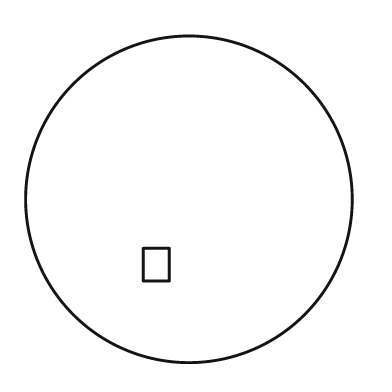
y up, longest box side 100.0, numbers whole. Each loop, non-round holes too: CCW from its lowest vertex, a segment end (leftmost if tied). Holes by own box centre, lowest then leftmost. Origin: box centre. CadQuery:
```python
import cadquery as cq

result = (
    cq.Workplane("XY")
    .moveTo(0.0, 0.0)
    .circle(50.0)
    .moveTo(-14.0, -25.0)
    .lineTo(-6.0, -25.0)
    .lineTo(-6.0, -15.0)
    .lineTo(-14.0, -15.0)
    .close()
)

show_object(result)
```